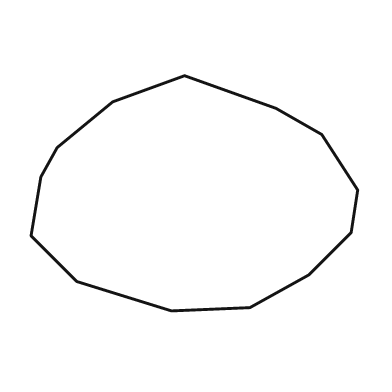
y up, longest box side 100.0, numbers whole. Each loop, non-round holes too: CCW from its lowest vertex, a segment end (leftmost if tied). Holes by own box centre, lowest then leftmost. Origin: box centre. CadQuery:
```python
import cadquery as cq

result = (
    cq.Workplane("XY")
    .moveTo(-7.0, -36.0)
    .lineTo(17.0, -35.0)
    .lineTo(35.0, -25.0)
    .lineTo(48.0, -12.0)
    .lineTo(50.0, 1.0)
    .lineTo(39.0, 18.0)
    .lineTo(25.0, 26.0)
    .lineTo(-3.0, 36.0)
    .lineTo(-25.0, 28.0)
    .lineTo(-42.0, 14.0)
    .lineTo(-47.0, 5.0)
    .lineTo(-50.0, -13.0)
    .lineTo(-36.0, -27.0)
    .close()
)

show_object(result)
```